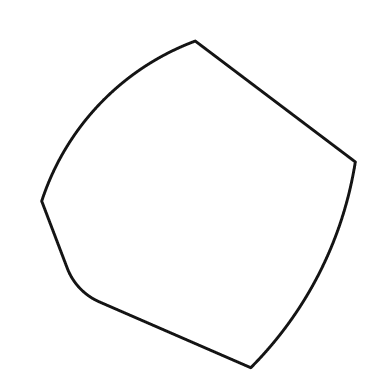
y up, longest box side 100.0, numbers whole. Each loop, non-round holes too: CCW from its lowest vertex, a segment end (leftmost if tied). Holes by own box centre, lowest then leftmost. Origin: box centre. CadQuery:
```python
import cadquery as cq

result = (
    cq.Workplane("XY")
    .moveTo(16.0, -50.0)
    .threePointArc((37.0, -21.0), (48.0, 13.0))
    .lineTo(-1.0, 50.0)
    .threePointArc((-30.0, 31.0), (-48.0, 1.0))
    .lineTo(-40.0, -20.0)
    .threePointArc((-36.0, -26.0), (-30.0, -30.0))
    .close()
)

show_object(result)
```